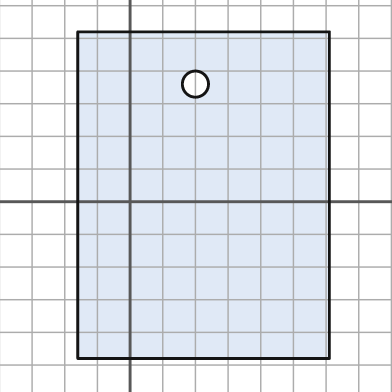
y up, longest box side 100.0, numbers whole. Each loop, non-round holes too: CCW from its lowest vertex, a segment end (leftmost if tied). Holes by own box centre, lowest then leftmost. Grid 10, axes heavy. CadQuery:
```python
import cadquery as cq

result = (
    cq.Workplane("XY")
    .moveTo(-16.0, -48.0)
    .lineTo(61.0, -48.0)
    .lineTo(61.0, 52.0)
    .lineTo(-16.0, 52.0)
    .close()
    .moveTo(20.0, 36.0)
    .circle(4.0)
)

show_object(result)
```